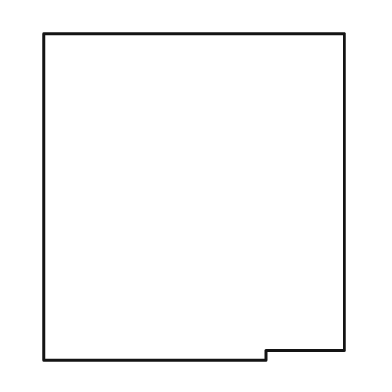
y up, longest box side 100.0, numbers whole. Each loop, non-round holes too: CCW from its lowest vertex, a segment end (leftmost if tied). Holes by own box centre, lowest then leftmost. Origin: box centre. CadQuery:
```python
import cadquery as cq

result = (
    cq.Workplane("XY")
    .moveTo(-46.0, -50.0)
    .lineTo(22.0, -50.0)
    .lineTo(22.0, -47.0)
    .lineTo(46.0, -47.0)
    .lineTo(46.0, 50.0)
    .lineTo(-46.0, 50.0)
    .close()
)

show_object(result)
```